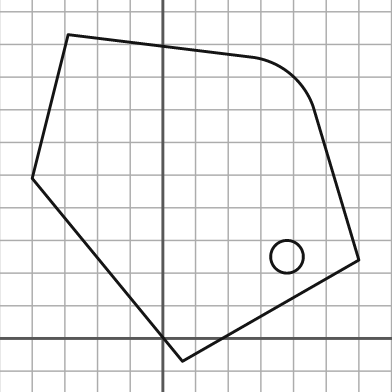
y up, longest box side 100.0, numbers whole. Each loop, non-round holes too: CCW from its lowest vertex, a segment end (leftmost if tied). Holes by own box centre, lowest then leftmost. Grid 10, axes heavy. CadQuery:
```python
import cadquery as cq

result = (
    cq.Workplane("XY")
    .moveTo(6.0, -7.0)
    .lineTo(60.0, 24.0)
    .lineTo(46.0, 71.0)
    .threePointArc((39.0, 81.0), (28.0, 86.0))
    .lineTo(-29.0, 93.0)
    .lineTo(-40.0, 49.0)
    .close()
    .moveTo(38.0, 25.0)
    .circle(5.0)
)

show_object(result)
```